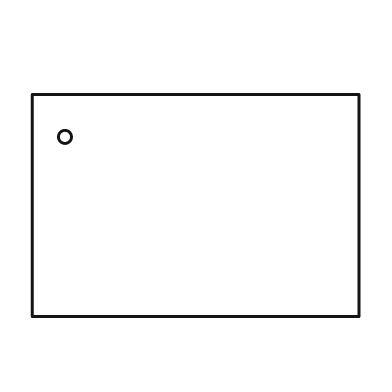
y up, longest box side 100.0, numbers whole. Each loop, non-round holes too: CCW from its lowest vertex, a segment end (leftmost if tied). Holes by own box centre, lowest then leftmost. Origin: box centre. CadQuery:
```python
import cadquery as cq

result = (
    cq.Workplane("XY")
    .moveTo(-50.0, -34.0)
    .lineTo(50.0, -34.0)
    .lineTo(50.0, 34.0)
    .lineTo(-50.0, 34.0)
    .close()
    .moveTo(-40.0, 21.0)
    .circle(2.0)
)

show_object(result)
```